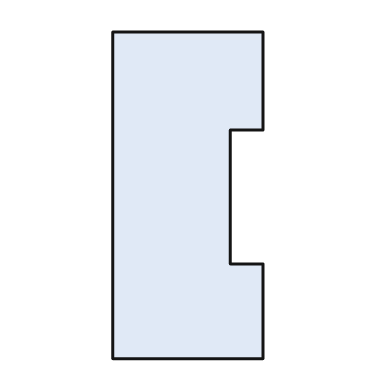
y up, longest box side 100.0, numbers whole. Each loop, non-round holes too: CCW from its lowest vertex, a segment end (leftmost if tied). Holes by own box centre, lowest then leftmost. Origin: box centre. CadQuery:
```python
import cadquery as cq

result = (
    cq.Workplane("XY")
    .moveTo(-23.0, -50.0)
    .lineTo(23.0, -50.0)
    .lineTo(23.0, -21.0)
    .lineTo(13.0, -21.0)
    .lineTo(13.0, 20.0)
    .lineTo(23.0, 20.0)
    .lineTo(23.0, 50.0)
    .lineTo(-23.0, 50.0)
    .close()
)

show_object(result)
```